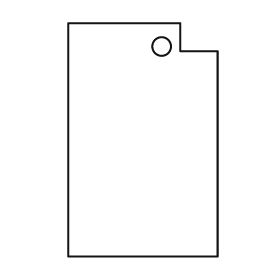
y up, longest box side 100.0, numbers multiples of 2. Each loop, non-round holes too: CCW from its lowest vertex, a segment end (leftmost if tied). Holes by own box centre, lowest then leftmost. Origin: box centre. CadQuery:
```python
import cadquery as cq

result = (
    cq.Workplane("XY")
    .moveTo(-32.0, -50.0)
    .lineTo(32.0, -50.0)
    .lineTo(32.0, 38.0)
    .lineTo(16.0, 38.0)
    .lineTo(16.0, 50.0)
    .lineTo(-32.0, 50.0)
    .close()
    .moveTo(8.0, 40.0)
    .circle(4.0)
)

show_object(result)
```